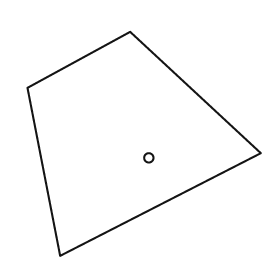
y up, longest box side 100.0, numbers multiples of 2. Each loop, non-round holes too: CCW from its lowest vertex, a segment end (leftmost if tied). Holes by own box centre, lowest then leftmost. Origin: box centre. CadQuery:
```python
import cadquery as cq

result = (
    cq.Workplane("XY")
    .moveTo(-36.0, -48.0)
    .lineTo(50.0, -4.0)
    .lineTo(-6.0, 48.0)
    .lineTo(-50.0, 24.0)
    .close()
    .moveTo(2.0, -6.0)
    .circle(2.0)
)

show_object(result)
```